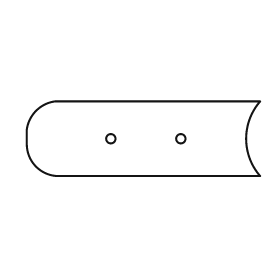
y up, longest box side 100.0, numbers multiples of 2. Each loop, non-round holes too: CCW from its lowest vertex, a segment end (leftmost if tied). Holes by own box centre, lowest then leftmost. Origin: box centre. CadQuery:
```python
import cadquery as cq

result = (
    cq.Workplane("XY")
    .moveTo(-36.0, -16.0)
    .lineTo(50.0, -16.0)
    .threePointArc((44.0, 0.0), (50.0, 16.0))
    .lineTo(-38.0, 16.0)
    .threePointArc((-46.0, 12.0), (-50.0, 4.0))
    .lineTo(-50.0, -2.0)
    .threePointArc((-46.0, -12.0), (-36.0, -16.0))
    .close()
    .moveTo(-14.0, 0.0)
    .circle(2.0)
    .moveTo(16.0, 0.0)
    .circle(2.0)
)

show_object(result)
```